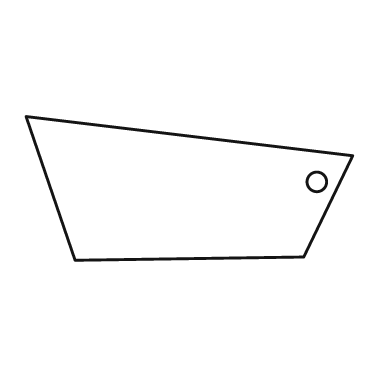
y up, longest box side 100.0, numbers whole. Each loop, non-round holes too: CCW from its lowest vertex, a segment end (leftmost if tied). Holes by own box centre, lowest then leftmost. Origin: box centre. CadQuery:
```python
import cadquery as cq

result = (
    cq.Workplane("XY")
    .moveTo(-35.0, -22.0)
    .lineTo(35.0, -21.0)
    .lineTo(50.0, 10.0)
    .lineTo(-50.0, 22.0)
    .close()
    .moveTo(39.0, 2.0)
    .circle(3.0)
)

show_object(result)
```